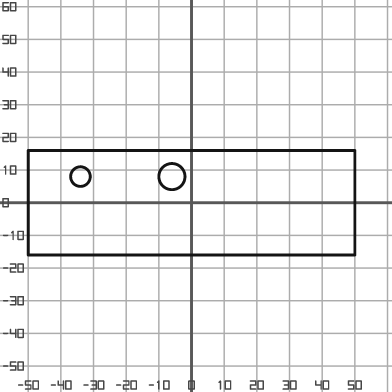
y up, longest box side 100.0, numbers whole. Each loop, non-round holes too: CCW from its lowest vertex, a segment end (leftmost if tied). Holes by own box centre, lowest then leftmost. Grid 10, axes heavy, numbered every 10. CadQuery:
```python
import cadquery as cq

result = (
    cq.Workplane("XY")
    .moveTo(-50.0, -16.0)
    .lineTo(50.0, -16.0)
    .lineTo(50.0, 16.0)
    .lineTo(-50.0, 16.0)
    .close()
    .moveTo(-34.0, 8.0)
    .circle(3.0)
    .moveTo(-6.0, 8.0)
    .circle(4.0)
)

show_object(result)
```